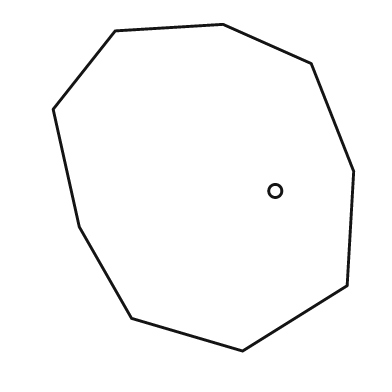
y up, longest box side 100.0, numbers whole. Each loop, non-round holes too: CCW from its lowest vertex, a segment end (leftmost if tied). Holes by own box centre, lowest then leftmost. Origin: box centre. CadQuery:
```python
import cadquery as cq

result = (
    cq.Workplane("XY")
    .moveTo(12.0, -50.0)
    .lineTo(44.0, -30.0)
    .lineTo(46.0, 5.0)
    .lineTo(33.0, 38.0)
    .lineTo(6.0, 50.0)
    .lineTo(-27.0, 48.0)
    .lineTo(-46.0, 24.0)
    .lineTo(-38.0, -12.0)
    .lineTo(-22.0, -40.0)
    .close()
    .moveTo(22.0, -1.0)
    .circle(2.0)
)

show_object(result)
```